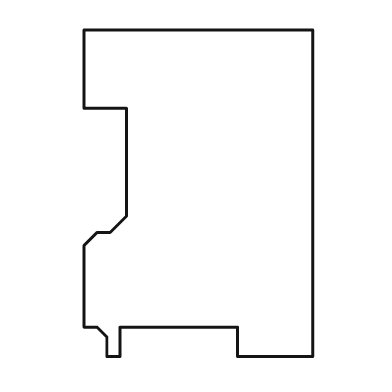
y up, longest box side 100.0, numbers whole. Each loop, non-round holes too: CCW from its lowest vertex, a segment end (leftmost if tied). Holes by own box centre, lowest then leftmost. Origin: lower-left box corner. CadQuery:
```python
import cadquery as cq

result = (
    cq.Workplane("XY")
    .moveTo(7.0, 0.0)
    .lineTo(11.0, 0.0)
    .lineTo(11.0, 9.0)
    .lineTo(47.0, 9.0)
    .lineTo(47.0, 0.0)
    .lineTo(70.0, 0.0)
    .lineTo(70.0, 100.0)
    .lineTo(0.0, 100.0)
    .lineTo(0.0, 76.0)
    .lineTo(13.0, 76.0)
    .lineTo(13.0, 43.0)
    .lineTo(8.0, 38.0)
    .lineTo(4.0, 38.0)
    .lineTo(0.0, 34.0)
    .lineTo(0.0, 9.0)
    .lineTo(4.0, 9.0)
    .lineTo(7.0, 6.0)
    .close()
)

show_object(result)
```